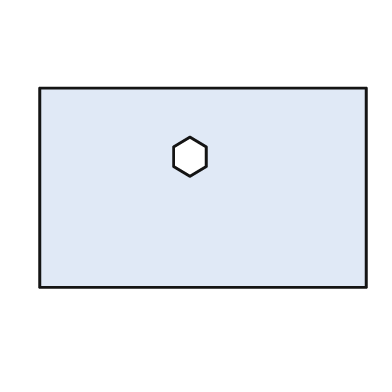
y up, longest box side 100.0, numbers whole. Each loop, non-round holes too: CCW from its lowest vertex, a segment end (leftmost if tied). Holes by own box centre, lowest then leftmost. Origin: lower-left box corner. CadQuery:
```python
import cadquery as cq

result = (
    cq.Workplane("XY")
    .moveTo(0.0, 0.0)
    .lineTo(100.0, 0.0)
    .lineTo(100.0, 61.0)
    .lineTo(0.0, 61.0)
    .close()
    .moveTo(46.0, 34.0)
    .lineTo(51.0, 37.0)
    .lineTo(51.0, 43.0)
    .lineTo(46.0, 46.0)
    .lineTo(41.0, 43.0)
    .lineTo(41.0, 37.0)
    .close()
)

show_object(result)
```